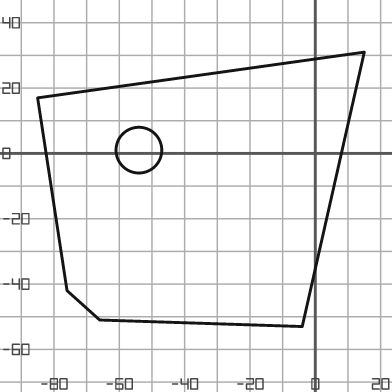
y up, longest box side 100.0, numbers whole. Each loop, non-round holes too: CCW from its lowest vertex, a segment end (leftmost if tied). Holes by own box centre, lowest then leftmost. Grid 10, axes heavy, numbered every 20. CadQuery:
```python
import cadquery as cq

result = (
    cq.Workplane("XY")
    .moveTo(-4.0, -53.0)
    .lineTo(15.0, 31.0)
    .lineTo(-85.0, 17.0)
    .lineTo(-76.0, -42.0)
    .lineTo(-66.0, -51.0)
    .close()
    .moveTo(-54.0, 1.0)
    .circle(7.0)
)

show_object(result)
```